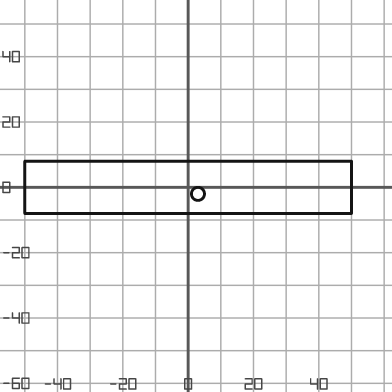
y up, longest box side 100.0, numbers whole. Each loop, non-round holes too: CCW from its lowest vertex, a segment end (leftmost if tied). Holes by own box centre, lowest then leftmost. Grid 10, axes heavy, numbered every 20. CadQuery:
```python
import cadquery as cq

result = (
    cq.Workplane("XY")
    .moveTo(-50.0, -8.0)
    .lineTo(50.0, -8.0)
    .lineTo(50.0, 8.0)
    .lineTo(-50.0, 8.0)
    .close()
    .moveTo(3.0, -2.0)
    .circle(2.0)
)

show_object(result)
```